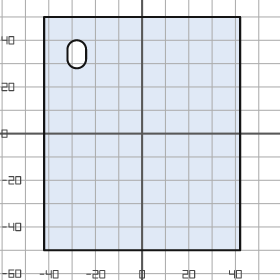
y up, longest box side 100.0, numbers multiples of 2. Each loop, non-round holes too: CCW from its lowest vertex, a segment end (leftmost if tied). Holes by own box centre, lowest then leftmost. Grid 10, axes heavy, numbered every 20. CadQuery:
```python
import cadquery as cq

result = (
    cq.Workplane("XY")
    .moveTo(-42.0, -50.0)
    .lineTo(42.0, -50.0)
    .lineTo(42.0, 50.0)
    .lineTo(-42.0, 50.0)
    .close()
    .moveTo(-32.0, 32.0)
    .threePointArc((-28.0, 28.0), (-24.0, 32.0))
    .lineTo(-24.0, 36.0)
    .threePointArc((-28.0, 40.0), (-32.0, 36.0))
    .close()
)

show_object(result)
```